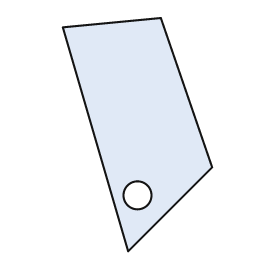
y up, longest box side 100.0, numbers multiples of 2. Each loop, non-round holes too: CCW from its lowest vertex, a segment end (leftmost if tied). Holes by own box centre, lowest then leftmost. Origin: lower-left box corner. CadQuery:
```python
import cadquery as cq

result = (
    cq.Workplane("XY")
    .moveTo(28.0, 0.0)
    .lineTo(64.0, 36.0)
    .lineTo(42.0, 100.0)
    .lineTo(0.0, 96.0)
    .close()
    .moveTo(32.0, 24.0)
    .circle(6.0)
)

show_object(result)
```